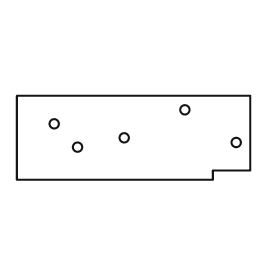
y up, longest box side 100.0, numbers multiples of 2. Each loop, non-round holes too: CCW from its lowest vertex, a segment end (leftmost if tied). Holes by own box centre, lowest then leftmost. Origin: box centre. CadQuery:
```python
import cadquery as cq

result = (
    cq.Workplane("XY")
    .moveTo(-50.0, -18.0)
    .lineTo(34.0, -18.0)
    .lineTo(34.0, -14.0)
    .lineTo(50.0, -14.0)
    .lineTo(50.0, 18.0)
    .lineTo(-50.0, 18.0)
    .close()
    .moveTo(-24.0, -4.0)
    .circle(2.0)
    .moveTo(44.0, -2.0)
    .circle(2.0)
    .moveTo(-4.0, 0.0)
    .circle(2.0)
    .moveTo(-34.0, 6.0)
    .circle(2.0)
    .moveTo(22.0, 12.0)
    .circle(2.0)
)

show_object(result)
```